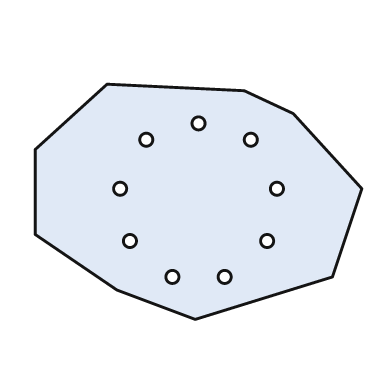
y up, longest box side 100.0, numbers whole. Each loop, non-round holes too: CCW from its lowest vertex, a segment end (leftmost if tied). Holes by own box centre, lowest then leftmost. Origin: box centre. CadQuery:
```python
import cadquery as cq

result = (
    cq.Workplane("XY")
    .moveTo(-1.0, -36.0)
    .lineTo(41.0, -23.0)
    .lineTo(50.0, 4.0)
    .lineTo(29.0, 27.0)
    .lineTo(14.0, 34.0)
    .lineTo(-28.0, 36.0)
    .lineTo(-50.0, 16.0)
    .lineTo(-50.0, -10.0)
    .lineTo(-25.0, -27.0)
    .close()
    .moveTo(-8.0, -23.0)
    .circle(2.0)
    .moveTo(8.0, -23.0)
    .circle(2.0)
    .moveTo(-21.0, -12.0)
    .circle(2.0)
    .moveTo(21.0, -12.0)
    .circle(2.0)
    .moveTo(-24.0, 4.0)
    .circle(2.0)
    .moveTo(24.0, 4.0)
    .circle(2.0)
    .moveTo(-16.0, 19.0)
    .circle(2.0)
    .moveTo(16.0, 19.0)
    .circle(2.0)
    .moveTo(0.0, 24.0)
    .circle(2.0)
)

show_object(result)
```